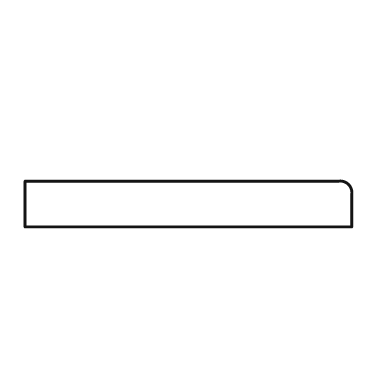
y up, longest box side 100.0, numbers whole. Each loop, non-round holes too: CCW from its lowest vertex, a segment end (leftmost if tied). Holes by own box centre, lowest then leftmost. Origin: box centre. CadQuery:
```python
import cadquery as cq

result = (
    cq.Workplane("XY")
    .moveTo(-50.0, -7.0)
    .lineTo(50.0, -7.0)
    .lineTo(50.0, 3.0)
    .threePointArc((49.0, 6.0), (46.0, 7.0))
    .lineTo(-50.0, 7.0)
    .close()
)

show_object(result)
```